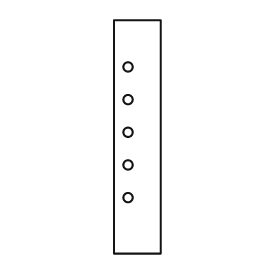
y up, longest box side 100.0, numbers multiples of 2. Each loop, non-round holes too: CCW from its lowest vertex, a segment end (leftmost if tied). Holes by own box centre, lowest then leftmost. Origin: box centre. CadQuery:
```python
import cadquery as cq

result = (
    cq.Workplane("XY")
    .moveTo(-10.0, -50.0)
    .lineTo(10.0, -50.0)
    .lineTo(10.0, 50.0)
    .lineTo(-10.0, 50.0)
    .close()
    .moveTo(-4.0, -26.0)
    .circle(2.0)
    .moveTo(-4.0, -12.0)
    .circle(2.0)
    .moveTo(-4.0, 2.0)
    .circle(2.0)
    .moveTo(-4.0, 16.0)
    .circle(2.0)
    .moveTo(-4.0, 30.0)
    .circle(2.0)
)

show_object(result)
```